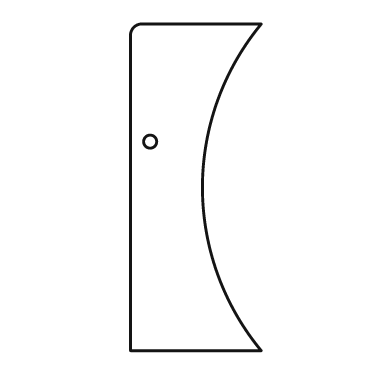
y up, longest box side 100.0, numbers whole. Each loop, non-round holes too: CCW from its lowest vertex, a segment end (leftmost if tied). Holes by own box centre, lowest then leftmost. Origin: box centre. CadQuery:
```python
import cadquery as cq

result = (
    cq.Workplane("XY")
    .moveTo(-20.0, -50.0)
    .lineTo(20.0, -50.0)
    .threePointArc((2.0, 0.0), (20.0, 50.0))
    .lineTo(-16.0, 50.0)
    .threePointArc((-19.0, 49.0), (-20.0, 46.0))
    .close()
    .moveTo(-14.0, 14.0)
    .circle(2.0)
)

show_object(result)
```